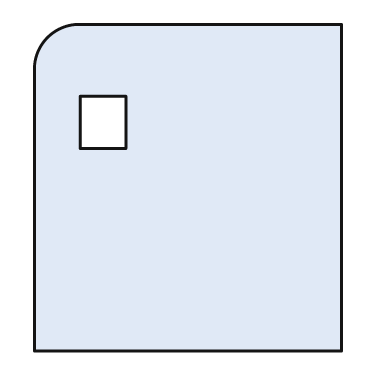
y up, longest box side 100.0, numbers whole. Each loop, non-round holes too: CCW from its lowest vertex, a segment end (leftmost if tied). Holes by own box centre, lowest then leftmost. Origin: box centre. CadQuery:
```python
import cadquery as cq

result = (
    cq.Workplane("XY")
    .moveTo(-47.0, -50.0)
    .lineTo(47.0, -50.0)
    .lineTo(47.0, 50.0)
    .lineTo(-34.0, 50.0)
    .threePointArc((-43.0, 46.0), (-47.0, 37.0))
    .close()
    .moveTo(-33.0, 12.0)
    .lineTo(-19.0, 12.0)
    .lineTo(-19.0, 28.0)
    .lineTo(-33.0, 28.0)
    .close()
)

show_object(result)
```